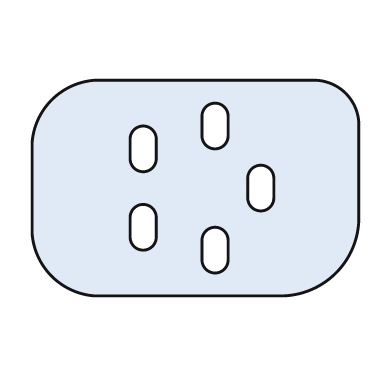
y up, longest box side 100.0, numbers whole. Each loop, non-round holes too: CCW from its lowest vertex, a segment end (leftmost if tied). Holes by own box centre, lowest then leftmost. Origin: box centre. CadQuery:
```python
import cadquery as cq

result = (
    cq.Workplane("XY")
    .moveTo(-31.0, -33.0)
    .lineTo(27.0, -33.0)
    .threePointArc((43.0, -26.0), (50.0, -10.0))
    .lineTo(50.0, 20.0)
    .threePointArc((46.0, 29.0), (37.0, 33.0))
    .lineTo(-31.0, 33.0)
    .threePointArc((-44.0, 27.0), (-50.0, 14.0))
    .lineTo(-50.0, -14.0)
    .threePointArc((-44.0, -27.0), (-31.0, -33.0))
    .close()
    .moveTo(2.0, -22.0)
    .threePointArc((6.0, -26.0), (10.0, -22.0))
    .lineTo(10.0, -16.0)
    .threePointArc((6.0, -12.0), (2.0, -16.0))
    .close()
    .moveTo(-20.0, -15.0)
    .threePointArc((-16.0, -19.0), (-12.0, -15.0))
    .lineTo(-12.0, -9.0)
    .threePointArc((-16.0, -5.0), (-20.0, -9.0))
    .close()
    .moveTo(16.0, -3.0)
    .threePointArc((20.0, -7.0), (24.0, -3.0))
    .lineTo(24.0, 3.0)
    .threePointArc((20.0, 7.0), (16.0, 3.0))
    .close()
    .moveTo(-20.0, 9.0)
    .threePointArc((-16.0, 5.0), (-12.0, 9.0))
    .lineTo(-12.0, 15.0)
    .threePointArc((-16.0, 19.0), (-20.0, 15.0))
    .close()
    .moveTo(2.0, 16.0)
    .threePointArc((6.0, 12.0), (10.0, 16.0))
    .lineTo(10.0, 22.0)
    .threePointArc((6.0, 26.0), (2.0, 22.0))
    .close()
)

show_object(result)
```